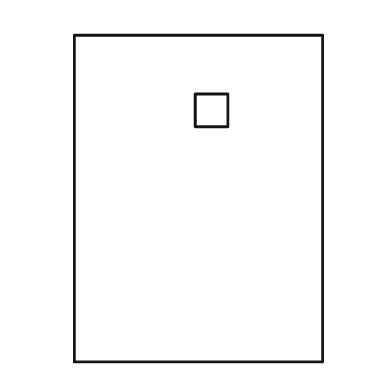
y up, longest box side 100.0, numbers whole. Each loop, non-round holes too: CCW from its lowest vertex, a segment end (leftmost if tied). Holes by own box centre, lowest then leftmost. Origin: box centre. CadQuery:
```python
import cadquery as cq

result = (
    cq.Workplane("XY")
    .moveTo(-38.0, -50.0)
    .lineTo(38.0, -50.0)
    .lineTo(38.0, 50.0)
    .lineTo(-38.0, 50.0)
    .close()
    .moveTo(-1.0, 22.0)
    .lineTo(9.0, 22.0)
    .lineTo(9.0, 32.0)
    .lineTo(-1.0, 32.0)
    .close()
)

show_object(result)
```